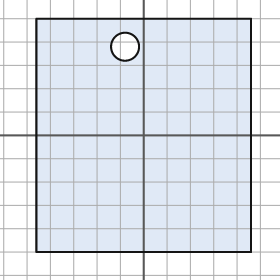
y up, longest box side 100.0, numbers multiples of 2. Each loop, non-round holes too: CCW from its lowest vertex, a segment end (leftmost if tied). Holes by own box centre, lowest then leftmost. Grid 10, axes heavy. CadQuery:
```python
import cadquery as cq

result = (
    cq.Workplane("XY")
    .moveTo(-46.0, -50.0)
    .lineTo(46.0, -50.0)
    .lineTo(46.0, 50.0)
    .lineTo(-46.0, 50.0)
    .close()
    .moveTo(-8.0, 38.0)
    .circle(6.0)
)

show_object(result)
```